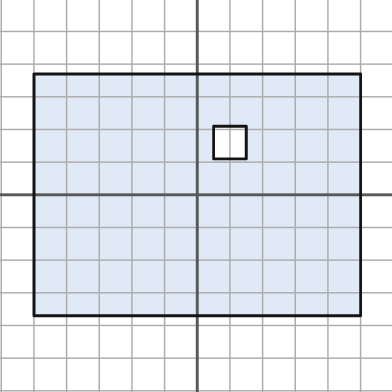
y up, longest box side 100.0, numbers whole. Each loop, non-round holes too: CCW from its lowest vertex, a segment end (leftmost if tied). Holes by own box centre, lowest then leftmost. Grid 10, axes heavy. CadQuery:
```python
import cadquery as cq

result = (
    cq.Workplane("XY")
    .moveTo(-50.0, -37.0)
    .lineTo(50.0, -37.0)
    .lineTo(50.0, 37.0)
    .lineTo(-50.0, 37.0)
    .close()
    .moveTo(5.0, 11.0)
    .lineTo(15.0, 11.0)
    .lineTo(15.0, 21.0)
    .lineTo(5.0, 21.0)
    .close()
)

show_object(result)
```